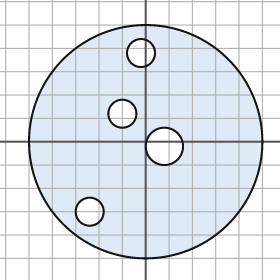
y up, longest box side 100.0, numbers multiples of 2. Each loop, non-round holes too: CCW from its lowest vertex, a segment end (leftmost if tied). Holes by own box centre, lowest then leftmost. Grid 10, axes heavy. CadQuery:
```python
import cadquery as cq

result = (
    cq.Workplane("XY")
    .moveTo(0.0, 0.0)
    .circle(50.0)
    .moveTo(-24.0, -30.0)
    .circle(6.0)
    .moveTo(8.0, -2.0)
    .circle(8.0)
    .moveTo(-10.0, 12.0)
    .circle(6.0)
    .moveTo(-2.0, 38.0)
    .circle(6.0)
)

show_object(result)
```